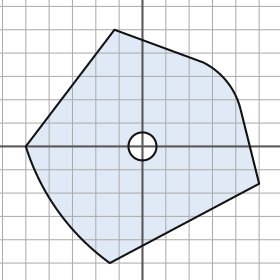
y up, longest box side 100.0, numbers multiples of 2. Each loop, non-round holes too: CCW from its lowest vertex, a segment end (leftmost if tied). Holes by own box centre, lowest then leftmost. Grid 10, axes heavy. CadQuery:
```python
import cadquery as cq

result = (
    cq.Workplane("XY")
    .moveTo(-14.0, -50.0)
    .lineTo(50.0, -16.0)
    .lineTo(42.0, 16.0)
    .threePointArc((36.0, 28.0), (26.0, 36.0))
    .lineTo(-12.0, 50.0)
    .lineTo(-50.0, 0.0)
    .threePointArc((-36.0, -28.0), (-14.0, -50.0))
    .close()
    .moveTo(0.0, 0.0)
    .circle(6.0)
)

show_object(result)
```